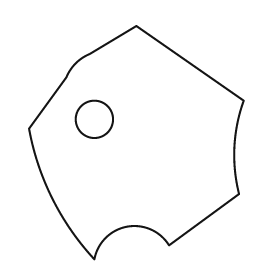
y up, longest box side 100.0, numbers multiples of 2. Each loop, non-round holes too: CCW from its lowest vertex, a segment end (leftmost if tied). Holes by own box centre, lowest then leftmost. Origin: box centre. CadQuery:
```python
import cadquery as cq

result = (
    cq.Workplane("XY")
    .moveTo(-18.0, -50.0)
    .threePointArc((-4.0, -36.0), (14.0, -44.0))
    .lineTo(44.0, -22.0)
    .threePointArc((42.0, -2.0), (46.0, 18.0))
    .lineTo(0.0, 50.0)
    .lineTo(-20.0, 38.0)
    .threePointArc((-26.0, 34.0), (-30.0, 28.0))
    .lineTo(-46.0, 6.0)
    .threePointArc((-36.0, -24.0), (-18.0, -50.0))
    .close()
    .moveTo(-18.0, 10.0)
    .circle(8.0)
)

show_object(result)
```